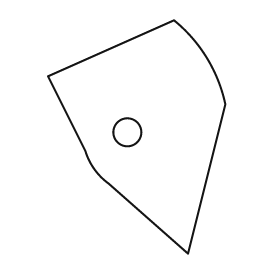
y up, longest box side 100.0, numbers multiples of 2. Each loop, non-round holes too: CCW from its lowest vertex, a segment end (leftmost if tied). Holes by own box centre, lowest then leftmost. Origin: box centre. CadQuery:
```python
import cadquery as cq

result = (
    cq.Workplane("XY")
    .moveTo(22.0, -50.0)
    .lineTo(38.0, 14.0)
    .threePointArc((30.0, 34.0), (16.0, 50.0))
    .lineTo(-38.0, 26.0)
    .lineTo(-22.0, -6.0)
    .threePointArc((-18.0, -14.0), (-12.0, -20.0))
    .close()
    .moveTo(-4.0, 2.0)
    .circle(6.0)
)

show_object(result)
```